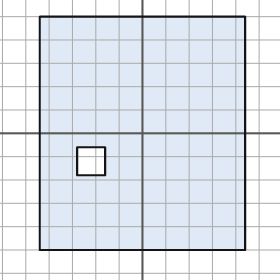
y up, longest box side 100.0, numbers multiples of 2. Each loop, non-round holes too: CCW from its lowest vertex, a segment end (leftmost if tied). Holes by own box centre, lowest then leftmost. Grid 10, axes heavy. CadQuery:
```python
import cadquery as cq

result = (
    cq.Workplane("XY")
    .moveTo(-44.0, -50.0)
    .lineTo(44.0, -50.0)
    .lineTo(44.0, 50.0)
    .lineTo(-44.0, 50.0)
    .close()
    .moveTo(-28.0, -18.0)
    .lineTo(-16.0, -18.0)
    .lineTo(-16.0, -6.0)
    .lineTo(-28.0, -6.0)
    .close()
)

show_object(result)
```